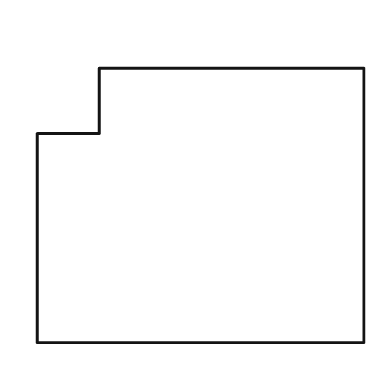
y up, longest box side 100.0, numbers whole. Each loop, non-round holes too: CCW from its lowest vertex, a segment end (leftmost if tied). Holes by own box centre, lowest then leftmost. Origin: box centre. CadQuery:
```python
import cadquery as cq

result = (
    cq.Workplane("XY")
    .moveTo(-50.0, -42.0)
    .lineTo(50.0, -42.0)
    .lineTo(50.0, 42.0)
    .lineTo(-31.0, 42.0)
    .lineTo(-31.0, 22.0)
    .lineTo(-50.0, 22.0)
    .close()
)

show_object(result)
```